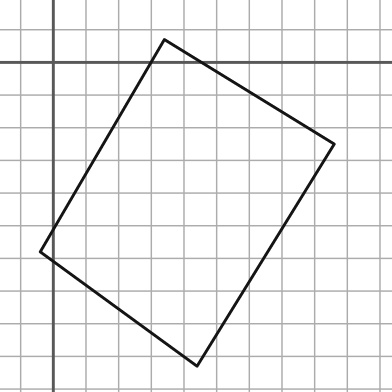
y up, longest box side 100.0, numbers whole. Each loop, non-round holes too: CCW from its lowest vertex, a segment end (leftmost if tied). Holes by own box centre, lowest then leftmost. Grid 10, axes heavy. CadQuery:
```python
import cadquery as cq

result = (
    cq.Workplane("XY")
    .moveTo(44.0, -93.0)
    .lineTo(86.0, -25.0)
    .lineTo(34.0, 7.0)
    .lineTo(-4.0, -58.0)
    .close()
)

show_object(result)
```